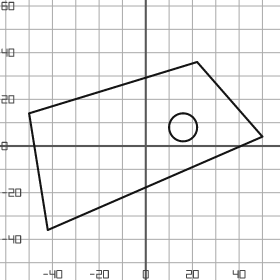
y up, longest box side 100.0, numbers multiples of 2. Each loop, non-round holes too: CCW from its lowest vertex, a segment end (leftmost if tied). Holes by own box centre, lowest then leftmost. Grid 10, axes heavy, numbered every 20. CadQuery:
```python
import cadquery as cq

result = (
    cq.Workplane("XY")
    .moveTo(-42.0, -36.0)
    .lineTo(50.0, 4.0)
    .lineTo(22.0, 36.0)
    .lineTo(-50.0, 14.0)
    .close()
    .moveTo(16.0, 8.0)
    .circle(6.0)
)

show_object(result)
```